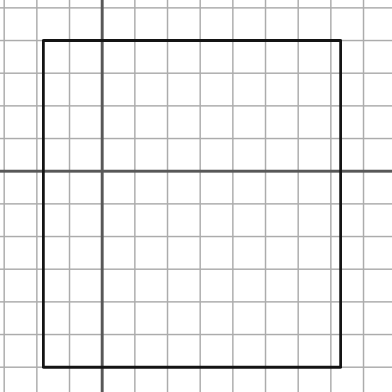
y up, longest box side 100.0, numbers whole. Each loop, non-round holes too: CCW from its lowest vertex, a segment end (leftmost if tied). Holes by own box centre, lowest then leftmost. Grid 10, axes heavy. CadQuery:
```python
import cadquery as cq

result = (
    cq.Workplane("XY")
    .moveTo(-18.0, -60.0)
    .lineTo(73.0, -60.0)
    .lineTo(73.0, 40.0)
    .lineTo(-18.0, 40.0)
    .close()
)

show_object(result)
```